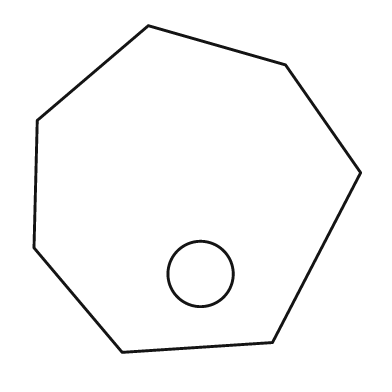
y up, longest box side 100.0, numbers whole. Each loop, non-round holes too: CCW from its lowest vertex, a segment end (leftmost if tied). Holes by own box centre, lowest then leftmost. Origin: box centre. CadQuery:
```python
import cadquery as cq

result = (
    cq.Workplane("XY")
    .moveTo(-23.0, -50.0)
    .lineTo(23.0, -47.0)
    .lineTo(50.0, 5.0)
    .lineTo(27.0, 38.0)
    .lineTo(-15.0, 50.0)
    .lineTo(-49.0, 21.0)
    .lineTo(-50.0, -18.0)
    .close()
    .moveTo(1.0, -26.0)
    .circle(10.0)
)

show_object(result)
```